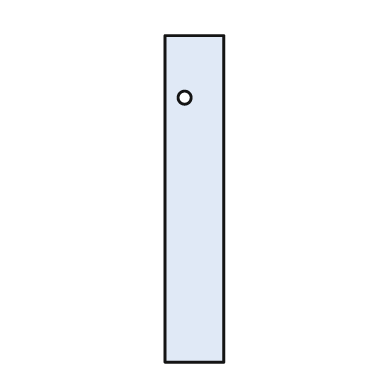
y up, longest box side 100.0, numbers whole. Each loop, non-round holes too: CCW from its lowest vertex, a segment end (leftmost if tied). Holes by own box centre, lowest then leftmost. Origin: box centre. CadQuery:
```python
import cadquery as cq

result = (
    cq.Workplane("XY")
    .moveTo(-9.0, -50.0)
    .lineTo(9.0, -50.0)
    .lineTo(9.0, 50.0)
    .lineTo(-9.0, 50.0)
    .close()
    .moveTo(-3.0, 31.0)
    .circle(2.0)
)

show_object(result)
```